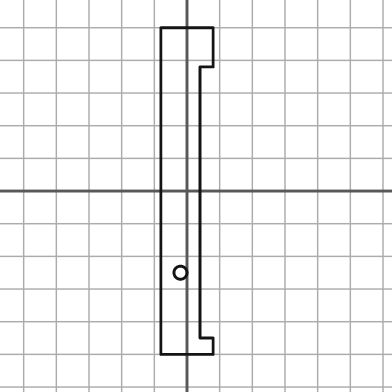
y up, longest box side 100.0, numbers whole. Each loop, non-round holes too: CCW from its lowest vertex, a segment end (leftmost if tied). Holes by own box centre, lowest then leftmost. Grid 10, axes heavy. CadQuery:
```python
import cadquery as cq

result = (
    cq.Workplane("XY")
    .moveTo(-8.0, -50.0)
    .lineTo(8.0, -50.0)
    .lineTo(8.0, -45.0)
    .lineTo(4.0, -45.0)
    .lineTo(4.0, 38.0)
    .lineTo(8.0, 38.0)
    .lineTo(8.0, 50.0)
    .lineTo(-8.0, 50.0)
    .close()
    .moveTo(-2.0, -25.0)
    .circle(2.0)
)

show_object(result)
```